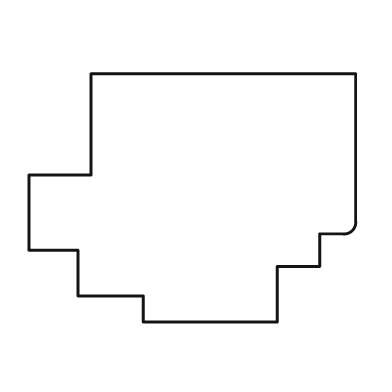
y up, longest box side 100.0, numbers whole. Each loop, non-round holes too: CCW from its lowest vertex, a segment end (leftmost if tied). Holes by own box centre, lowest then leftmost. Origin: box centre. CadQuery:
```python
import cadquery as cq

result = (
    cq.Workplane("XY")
    .moveTo(-15.0, -38.0)
    .lineTo(26.0, -38.0)
    .lineTo(26.0, -21.0)
    .lineTo(39.0, -21.0)
    .lineTo(39.0, -11.0)
    .lineTo(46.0, -11.0)
    .threePointArc((49.0, -10.0), (50.0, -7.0))
    .lineTo(50.0, 38.0)
    .lineTo(-31.0, 38.0)
    .lineTo(-31.0, 7.0)
    .lineTo(-50.0, 7.0)
    .lineTo(-50.0, -16.0)
    .lineTo(-35.0, -16.0)
    .lineTo(-35.0, -30.0)
    .lineTo(-15.0, -30.0)
    .close()
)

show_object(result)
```